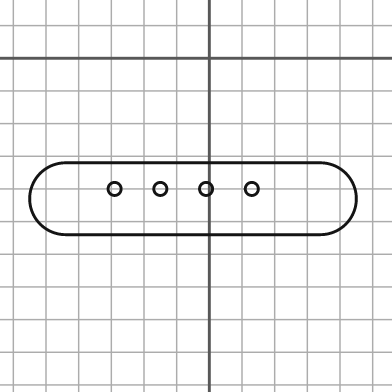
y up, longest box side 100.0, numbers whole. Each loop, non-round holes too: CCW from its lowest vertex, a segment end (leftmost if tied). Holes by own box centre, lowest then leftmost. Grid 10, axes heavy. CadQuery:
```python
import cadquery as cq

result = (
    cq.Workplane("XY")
    .moveTo(-44.0, -54.0)
    .lineTo(34.0, -54.0)
    .threePointArc((45.0, -43.0), (34.0, -32.0))
    .lineTo(-44.0, -32.0)
    .threePointArc((-55.0, -43.0), (-44.0, -54.0))
    .close()
    .moveTo(-29.0, -40.0)
    .circle(2.0)
    .moveTo(-15.0, -40.0)
    .circle(2.0)
    .moveTo(-1.0, -40.0)
    .circle(2.0)
    .moveTo(13.0, -40.0)
    .circle(2.0)
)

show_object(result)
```